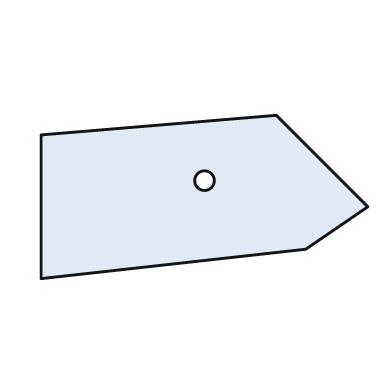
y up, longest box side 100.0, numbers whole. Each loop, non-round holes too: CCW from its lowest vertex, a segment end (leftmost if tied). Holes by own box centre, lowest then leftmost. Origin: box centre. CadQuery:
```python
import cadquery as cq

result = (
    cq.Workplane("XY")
    .moveTo(-50.0, -25.0)
    .lineTo(31.0, -16.0)
    .lineTo(50.0, -3.0)
    .lineTo(22.0, 25.0)
    .lineTo(-50.0, 19.0)
    .close()
    .moveTo(0.0, 5.0)
    .circle(3.0)
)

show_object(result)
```